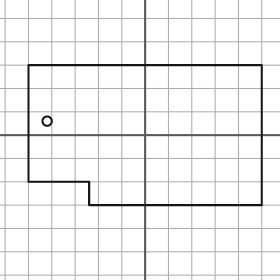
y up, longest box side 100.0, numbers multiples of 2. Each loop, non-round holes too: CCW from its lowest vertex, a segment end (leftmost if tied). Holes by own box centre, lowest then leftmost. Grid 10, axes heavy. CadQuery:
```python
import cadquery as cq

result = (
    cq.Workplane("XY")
    .moveTo(-24.0, -30.0)
    .lineTo(50.0, -30.0)
    .lineTo(50.0, 30.0)
    .lineTo(-50.0, 30.0)
    .lineTo(-50.0, -20.0)
    .lineTo(-24.0, -20.0)
    .close()
    .moveTo(-42.0, 6.0)
    .circle(2.0)
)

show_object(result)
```